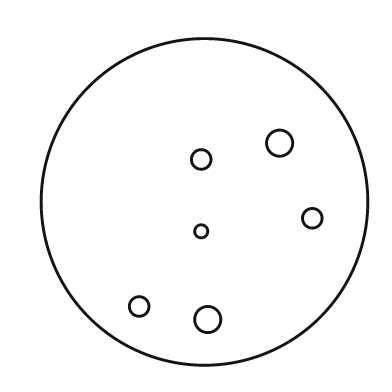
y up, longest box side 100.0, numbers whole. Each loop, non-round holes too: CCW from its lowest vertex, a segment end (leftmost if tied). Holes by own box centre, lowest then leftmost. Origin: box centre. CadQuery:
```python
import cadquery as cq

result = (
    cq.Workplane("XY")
    .moveTo(0.0, 0.0)
    .circle(50.0)
    .moveTo(1.0, -36.0)
    .circle(4.0)
    .moveTo(-20.0, -32.0)
    .circle(3.0)
    .moveTo(-1.0, -9.0)
    .circle(2.0)
    .moveTo(33.0, -5.0)
    .circle(3.0)
    .moveTo(-1.0, 13.0)
    .circle(3.0)
    .moveTo(23.0, 18.0)
    .circle(4.0)
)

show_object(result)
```